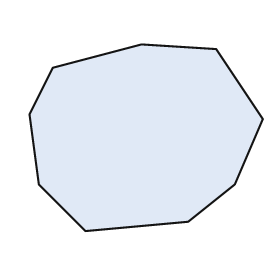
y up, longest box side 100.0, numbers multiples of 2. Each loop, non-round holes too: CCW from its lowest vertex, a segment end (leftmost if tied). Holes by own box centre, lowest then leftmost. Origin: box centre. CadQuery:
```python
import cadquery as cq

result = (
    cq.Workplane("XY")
    .moveTo(-26.0, -40.0)
    .lineTo(18.0, -36.0)
    .lineTo(38.0, -20.0)
    .lineTo(50.0, 8.0)
    .lineTo(30.0, 38.0)
    .lineTo(-2.0, 40.0)
    .lineTo(-40.0, 30.0)
    .lineTo(-50.0, 10.0)
    .lineTo(-46.0, -20.0)
    .close()
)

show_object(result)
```